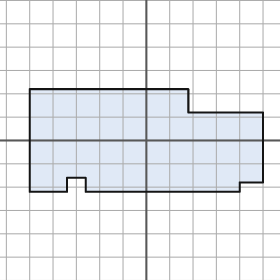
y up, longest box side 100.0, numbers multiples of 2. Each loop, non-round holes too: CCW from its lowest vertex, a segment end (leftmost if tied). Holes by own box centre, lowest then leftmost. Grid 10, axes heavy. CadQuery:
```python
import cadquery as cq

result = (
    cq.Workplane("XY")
    .moveTo(-50.0, -22.0)
    .lineTo(-34.0, -22.0)
    .lineTo(-34.0, -16.0)
    .lineTo(-26.0, -16.0)
    .lineTo(-26.0, -22.0)
    .lineTo(40.0, -22.0)
    .lineTo(40.0, -18.0)
    .lineTo(50.0, -18.0)
    .lineTo(50.0, 12.0)
    .lineTo(18.0, 12.0)
    .lineTo(18.0, 22.0)
    .lineTo(-50.0, 22.0)
    .close()
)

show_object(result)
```